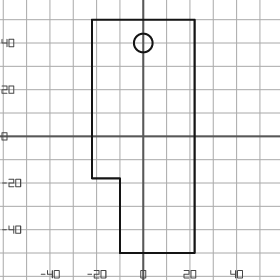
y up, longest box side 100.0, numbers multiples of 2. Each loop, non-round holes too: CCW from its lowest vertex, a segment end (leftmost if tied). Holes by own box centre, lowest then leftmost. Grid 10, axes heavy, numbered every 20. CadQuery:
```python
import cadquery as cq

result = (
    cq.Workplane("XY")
    .moveTo(-10.0, -50.0)
    .lineTo(22.0, -50.0)
    .lineTo(22.0, 50.0)
    .lineTo(-22.0, 50.0)
    .lineTo(-22.0, -18.0)
    .lineTo(-10.0, -18.0)
    .close()
    .moveTo(0.0, 40.0)
    .circle(4.0)
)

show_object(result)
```